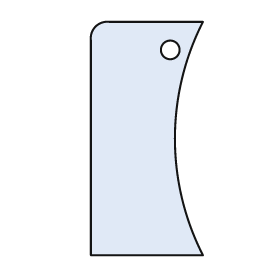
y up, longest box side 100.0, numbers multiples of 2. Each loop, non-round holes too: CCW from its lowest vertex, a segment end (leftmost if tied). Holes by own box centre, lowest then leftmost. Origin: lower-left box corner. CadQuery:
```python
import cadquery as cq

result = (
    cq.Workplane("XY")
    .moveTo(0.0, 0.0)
    .lineTo(48.0, 0.0)
    .threePointArc((36.0, 50.0), (48.0, 100.0))
    .lineTo(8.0, 100.0)
    .threePointArc((2.0, 98.0), (0.0, 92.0))
    .close()
    .moveTo(34.0, 88.0)
    .circle(4.0)
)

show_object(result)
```